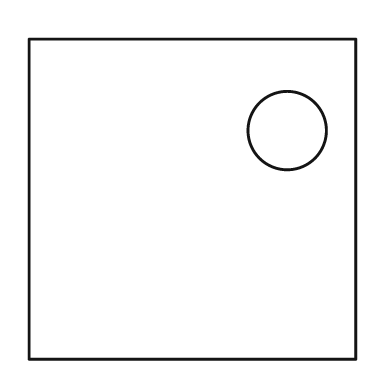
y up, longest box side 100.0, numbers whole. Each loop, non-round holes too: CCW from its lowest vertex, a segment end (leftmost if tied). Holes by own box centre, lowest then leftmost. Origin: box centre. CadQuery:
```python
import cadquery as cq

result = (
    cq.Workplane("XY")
    .moveTo(-50.0, -49.0)
    .lineTo(50.0, -49.0)
    .lineTo(50.0, 49.0)
    .lineTo(-50.0, 49.0)
    .close()
    .moveTo(29.0, 21.0)
    .circle(12.0)
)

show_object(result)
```